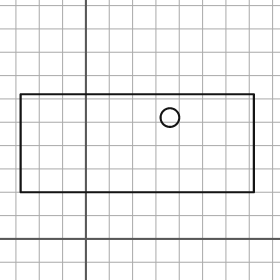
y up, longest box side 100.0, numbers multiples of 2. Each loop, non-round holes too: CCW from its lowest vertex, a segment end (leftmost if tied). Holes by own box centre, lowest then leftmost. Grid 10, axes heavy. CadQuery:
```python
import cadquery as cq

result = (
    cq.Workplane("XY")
    .moveTo(-28.0, 20.0)
    .lineTo(72.0, 20.0)
    .lineTo(72.0, 62.0)
    .lineTo(-28.0, 62.0)
    .close()
    .moveTo(36.0, 52.0)
    .circle(4.0)
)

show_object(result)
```